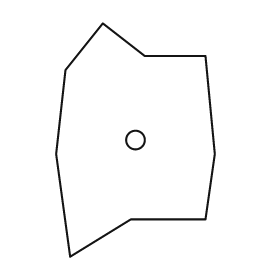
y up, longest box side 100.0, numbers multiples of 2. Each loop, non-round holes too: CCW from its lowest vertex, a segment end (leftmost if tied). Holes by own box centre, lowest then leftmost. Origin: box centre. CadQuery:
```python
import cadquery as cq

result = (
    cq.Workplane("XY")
    .moveTo(-28.0, -50.0)
    .lineTo(-2.0, -34.0)
    .lineTo(30.0, -34.0)
    .lineTo(34.0, -6.0)
    .lineTo(30.0, 36.0)
    .lineTo(4.0, 36.0)
    .lineTo(-14.0, 50.0)
    .lineTo(-30.0, 30.0)
    .lineTo(-34.0, -6.0)
    .close()
    .moveTo(0.0, 0.0)
    .circle(4.0)
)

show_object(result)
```